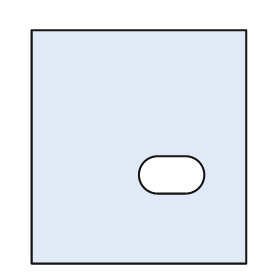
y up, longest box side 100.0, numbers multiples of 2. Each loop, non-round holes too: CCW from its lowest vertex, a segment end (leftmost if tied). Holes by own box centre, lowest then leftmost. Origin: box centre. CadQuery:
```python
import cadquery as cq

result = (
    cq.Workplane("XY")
    .moveTo(-46.0, -50.0)
    .lineTo(46.0, -50.0)
    .lineTo(46.0, 50.0)
    .lineTo(-46.0, 50.0)
    .close()
    .moveTo(8.0, -20.0)
    .lineTo(20.0, -20.0)
    .threePointArc((28.0, -12.0), (20.0, -4.0))
    .lineTo(8.0, -4.0)
    .threePointArc((0.0, -12.0), (8.0, -20.0))
    .close()
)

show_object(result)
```